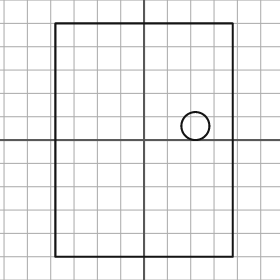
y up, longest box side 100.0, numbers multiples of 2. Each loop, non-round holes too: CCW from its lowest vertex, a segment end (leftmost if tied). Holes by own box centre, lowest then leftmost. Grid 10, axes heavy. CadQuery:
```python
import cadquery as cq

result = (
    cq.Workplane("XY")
    .moveTo(-38.0, -50.0)
    .lineTo(38.0, -50.0)
    .lineTo(38.0, 50.0)
    .lineTo(-38.0, 50.0)
    .close()
    .moveTo(22.0, 6.0)
    .circle(6.0)
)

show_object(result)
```